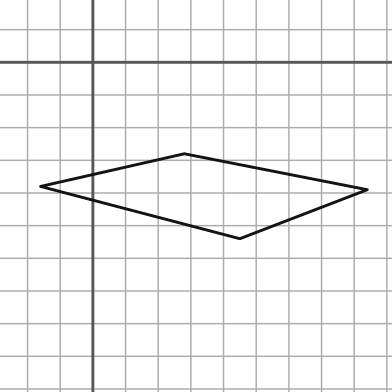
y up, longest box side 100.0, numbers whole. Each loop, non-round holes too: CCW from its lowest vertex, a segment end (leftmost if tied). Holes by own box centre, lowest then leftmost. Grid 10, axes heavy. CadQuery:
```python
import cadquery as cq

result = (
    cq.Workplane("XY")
    .moveTo(45.0, -54.0)
    .lineTo(84.0, -39.0)
    .lineTo(28.0, -28.0)
    .lineTo(-16.0, -38.0)
    .close()
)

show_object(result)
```